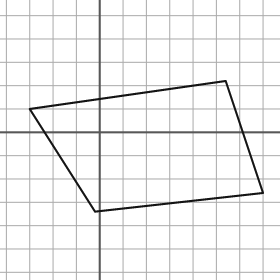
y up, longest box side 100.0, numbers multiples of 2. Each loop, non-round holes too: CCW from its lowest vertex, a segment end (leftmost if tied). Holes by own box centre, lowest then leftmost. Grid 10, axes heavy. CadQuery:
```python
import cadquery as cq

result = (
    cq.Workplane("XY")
    .moveTo(-2.0, -34.0)
    .lineTo(70.0, -26.0)
    .lineTo(54.0, 22.0)
    .lineTo(-30.0, 10.0)
    .close()
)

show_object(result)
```